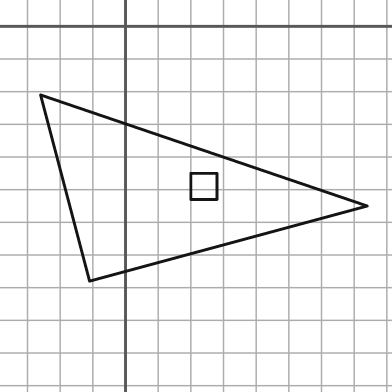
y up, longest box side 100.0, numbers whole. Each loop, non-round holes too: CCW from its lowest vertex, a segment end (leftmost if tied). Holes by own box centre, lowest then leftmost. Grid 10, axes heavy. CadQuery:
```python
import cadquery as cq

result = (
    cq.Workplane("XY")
    .moveTo(-11.0, -78.0)
    .lineTo(74.0, -55.0)
    .lineTo(-26.0, -21.0)
    .close()
    .moveTo(20.0, -53.0)
    .lineTo(28.0, -53.0)
    .lineTo(28.0, -45.0)
    .lineTo(20.0, -45.0)
    .close()
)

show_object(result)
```